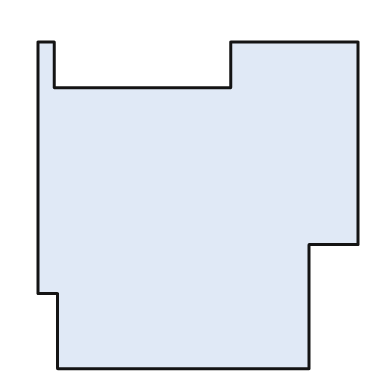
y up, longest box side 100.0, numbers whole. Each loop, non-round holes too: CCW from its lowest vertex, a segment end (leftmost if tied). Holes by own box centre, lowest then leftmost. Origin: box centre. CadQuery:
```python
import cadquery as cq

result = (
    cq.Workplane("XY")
    .moveTo(-43.0, -50.0)
    .lineTo(34.0, -50.0)
    .lineTo(34.0, -12.0)
    .lineTo(49.0, -12.0)
    .lineTo(49.0, 50.0)
    .lineTo(10.0, 50.0)
    .lineTo(10.0, 36.0)
    .lineTo(-44.0, 36.0)
    .lineTo(-44.0, 50.0)
    .lineTo(-49.0, 50.0)
    .lineTo(-49.0, -27.0)
    .lineTo(-43.0, -27.0)
    .close()
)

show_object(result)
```